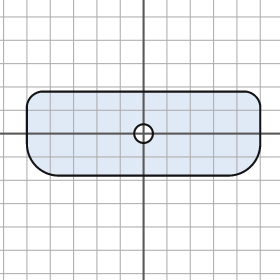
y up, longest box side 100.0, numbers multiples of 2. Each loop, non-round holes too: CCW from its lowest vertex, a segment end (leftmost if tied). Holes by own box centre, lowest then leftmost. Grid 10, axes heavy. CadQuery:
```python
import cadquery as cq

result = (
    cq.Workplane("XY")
    .moveTo(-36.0, -18.0)
    .lineTo(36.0, -18.0)
    .threePointArc((46.0, -14.0), (50.0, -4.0))
    .lineTo(50.0, 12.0)
    .threePointArc((48.0, 16.0), (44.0, 18.0))
    .lineTo(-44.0, 18.0)
    .threePointArc((-48.0, 16.0), (-50.0, 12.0))
    .lineTo(-50.0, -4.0)
    .threePointArc((-46.0, -14.0), (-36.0, -18.0))
    .close()
    .moveTo(0.0, 0.0)
    .circle(4.0)
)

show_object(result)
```